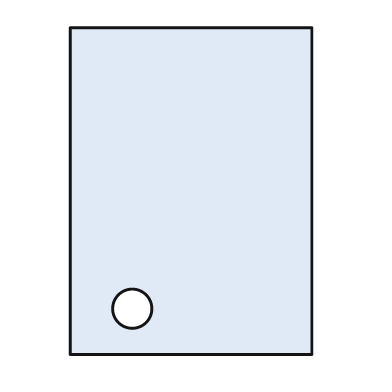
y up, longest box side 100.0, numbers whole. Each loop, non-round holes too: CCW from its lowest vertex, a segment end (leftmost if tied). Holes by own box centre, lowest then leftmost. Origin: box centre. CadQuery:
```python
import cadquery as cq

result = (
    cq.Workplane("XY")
    .moveTo(-37.0, -50.0)
    .lineTo(37.0, -50.0)
    .lineTo(37.0, 50.0)
    .lineTo(-37.0, 50.0)
    .close()
    .moveTo(-18.0, -36.0)
    .circle(6.0)
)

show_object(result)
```